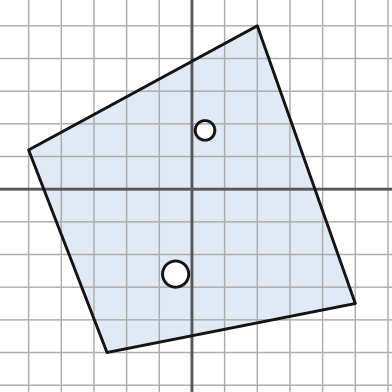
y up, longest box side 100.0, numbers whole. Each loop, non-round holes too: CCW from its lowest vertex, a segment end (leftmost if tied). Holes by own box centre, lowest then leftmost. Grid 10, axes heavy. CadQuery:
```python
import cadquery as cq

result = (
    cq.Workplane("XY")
    .moveTo(-26.0, -50.0)
    .lineTo(50.0, -35.0)
    .lineTo(20.0, 50.0)
    .lineTo(-50.0, 12.0)
    .close()
    .moveTo(-5.0, -26.0)
    .circle(4.0)
    .moveTo(4.0, 18.0)
    .circle(3.0)
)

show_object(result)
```